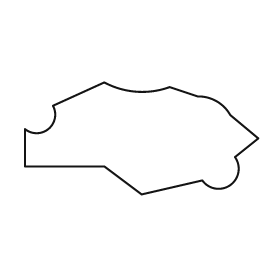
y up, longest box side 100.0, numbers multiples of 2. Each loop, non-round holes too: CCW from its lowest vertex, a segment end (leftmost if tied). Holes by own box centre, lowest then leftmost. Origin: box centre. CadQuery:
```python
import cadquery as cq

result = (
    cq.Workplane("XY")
    .moveTo(0.0, -24.0)
    .lineTo(26.0, -18.0)
    .threePointArc((38.0, -20.0), (40.0, -8.0))
    .lineTo(50.0, 0.0)
    .lineTo(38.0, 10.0)
    .threePointArc((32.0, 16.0), (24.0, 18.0))
    .lineTo(12.0, 22.0)
    .threePointArc((-2.0, 20.0), (-16.0, 24.0))
    .lineTo(-38.0, 14.0)
    .threePointArc((-40.0, 4.0), (-50.0, 4.0))
    .lineTo(-50.0, -12.0)
    .lineTo(-16.0, -12.0)
    .close()
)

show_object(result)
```